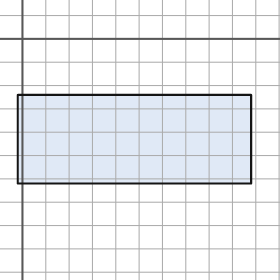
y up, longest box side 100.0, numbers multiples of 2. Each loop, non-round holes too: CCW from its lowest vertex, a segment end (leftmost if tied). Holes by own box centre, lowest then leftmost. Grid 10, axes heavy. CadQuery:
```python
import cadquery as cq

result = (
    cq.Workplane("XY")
    .moveTo(-2.0, -62.0)
    .lineTo(98.0, -62.0)
    .lineTo(98.0, -24.0)
    .lineTo(-2.0, -24.0)
    .close()
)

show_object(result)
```